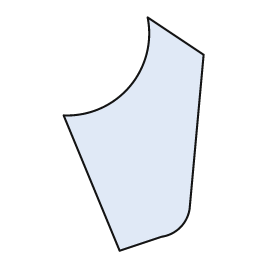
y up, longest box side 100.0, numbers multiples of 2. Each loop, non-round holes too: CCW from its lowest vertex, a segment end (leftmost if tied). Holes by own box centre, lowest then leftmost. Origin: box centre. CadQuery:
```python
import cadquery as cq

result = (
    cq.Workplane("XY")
    .moveTo(-6.0, -50.0)
    .lineTo(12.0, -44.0)
    .threePointArc((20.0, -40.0), (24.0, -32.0))
    .lineTo(30.0, 34.0)
    .lineTo(6.0, 50.0)
    .threePointArc((-2.0, 20.0), (-30.0, 8.0))
    .close()
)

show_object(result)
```